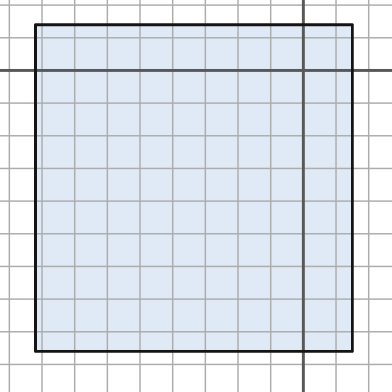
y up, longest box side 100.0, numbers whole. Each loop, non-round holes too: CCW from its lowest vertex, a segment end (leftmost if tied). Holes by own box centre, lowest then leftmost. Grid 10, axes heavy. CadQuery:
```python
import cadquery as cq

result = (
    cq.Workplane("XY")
    .moveTo(-82.0, -86.0)
    .lineTo(15.0, -86.0)
    .lineTo(15.0, 14.0)
    .lineTo(-82.0, 14.0)
    .close()
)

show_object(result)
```